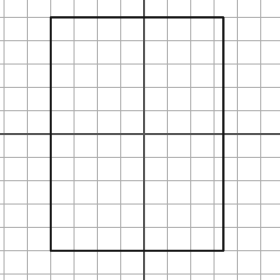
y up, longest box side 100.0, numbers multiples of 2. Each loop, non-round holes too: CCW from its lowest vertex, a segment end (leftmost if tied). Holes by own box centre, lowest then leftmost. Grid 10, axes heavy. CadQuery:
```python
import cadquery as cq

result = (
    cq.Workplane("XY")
    .moveTo(-40.0, -50.0)
    .lineTo(34.0, -50.0)
    .lineTo(34.0, 50.0)
    .lineTo(-40.0, 50.0)
    .close()
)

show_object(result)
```